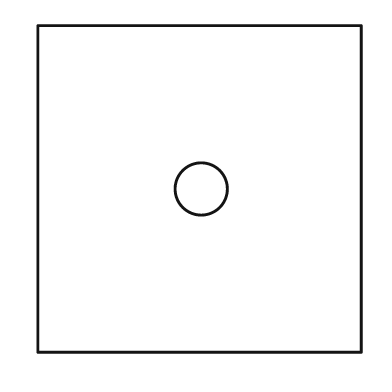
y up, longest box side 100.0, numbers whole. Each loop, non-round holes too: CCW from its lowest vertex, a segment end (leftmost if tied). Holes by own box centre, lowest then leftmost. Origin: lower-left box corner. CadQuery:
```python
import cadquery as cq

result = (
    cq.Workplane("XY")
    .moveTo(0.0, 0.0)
    .lineTo(99.0, 0.0)
    .lineTo(99.0, 100.0)
    .lineTo(0.0, 100.0)
    .close()
    .moveTo(50.0, 50.0)
    .circle(8.0)
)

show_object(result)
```